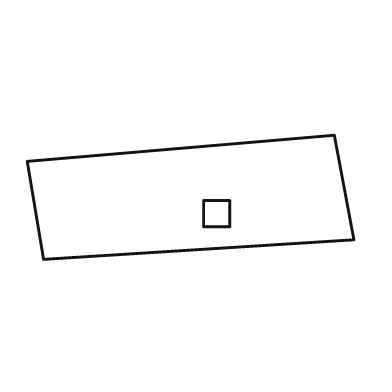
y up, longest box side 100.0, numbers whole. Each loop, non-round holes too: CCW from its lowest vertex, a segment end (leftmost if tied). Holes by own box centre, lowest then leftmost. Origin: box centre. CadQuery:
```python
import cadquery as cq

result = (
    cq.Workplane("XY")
    .moveTo(-45.0, -19.0)
    .lineTo(50.0, -13.0)
    .lineTo(44.0, 19.0)
    .lineTo(-50.0, 11.0)
    .close()
    .moveTo(4.0, -9.0)
    .lineTo(12.0, -9.0)
    .lineTo(12.0, -1.0)
    .lineTo(4.0, -1.0)
    .close()
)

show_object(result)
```